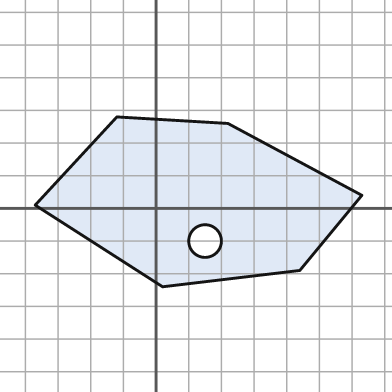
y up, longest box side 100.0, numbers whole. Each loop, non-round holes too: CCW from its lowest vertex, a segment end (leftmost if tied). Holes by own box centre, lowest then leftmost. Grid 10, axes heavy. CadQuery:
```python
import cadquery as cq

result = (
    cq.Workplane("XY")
    .moveTo(2.0, -24.0)
    .lineTo(44.0, -19.0)
    .lineTo(63.0, 4.0)
    .lineTo(22.0, 26.0)
    .lineTo(-12.0, 28.0)
    .lineTo(-37.0, 1.0)
    .close()
    .moveTo(15.0, -10.0)
    .circle(5.0)
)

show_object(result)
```